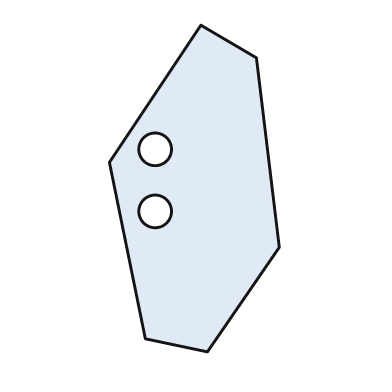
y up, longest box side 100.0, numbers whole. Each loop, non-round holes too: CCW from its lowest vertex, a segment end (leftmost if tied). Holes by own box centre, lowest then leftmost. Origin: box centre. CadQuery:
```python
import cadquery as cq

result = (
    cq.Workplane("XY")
    .moveTo(4.0, -50.0)
    .lineTo(26.0, -18.0)
    .lineTo(19.0, 40.0)
    .lineTo(2.0, 50.0)
    .lineTo(-26.0, 8.0)
    .lineTo(-15.0, -46.0)
    .close()
    .moveTo(-12.0, -7.0)
    .circle(5.0)
    .moveTo(-12.0, 12.0)
    .circle(5.0)
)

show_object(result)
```